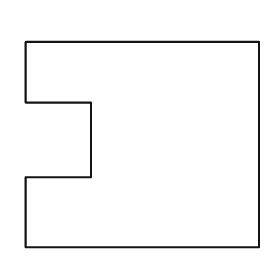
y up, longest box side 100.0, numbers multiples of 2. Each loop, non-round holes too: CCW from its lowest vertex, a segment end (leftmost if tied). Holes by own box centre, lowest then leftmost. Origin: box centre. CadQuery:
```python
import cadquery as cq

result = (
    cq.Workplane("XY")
    .moveTo(-50.0, -44.0)
    .lineTo(50.0, -44.0)
    .lineTo(50.0, 44.0)
    .lineTo(-50.0, 44.0)
    .lineTo(-50.0, 18.0)
    .lineTo(-22.0, 18.0)
    .lineTo(-22.0, -14.0)
    .lineTo(-50.0, -14.0)
    .close()
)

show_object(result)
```